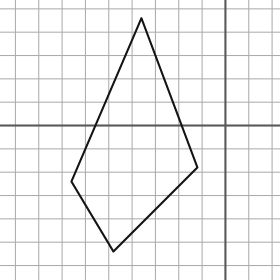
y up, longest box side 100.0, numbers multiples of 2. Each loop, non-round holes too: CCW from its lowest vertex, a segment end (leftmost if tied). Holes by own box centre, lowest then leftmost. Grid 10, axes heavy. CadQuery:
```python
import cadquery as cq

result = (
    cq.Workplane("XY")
    .moveTo(-48.0, -54.0)
    .lineTo(-12.0, -18.0)
    .lineTo(-36.0, 46.0)
    .lineTo(-66.0, -24.0)
    .close()
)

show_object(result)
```